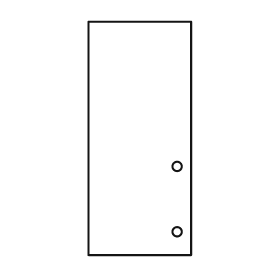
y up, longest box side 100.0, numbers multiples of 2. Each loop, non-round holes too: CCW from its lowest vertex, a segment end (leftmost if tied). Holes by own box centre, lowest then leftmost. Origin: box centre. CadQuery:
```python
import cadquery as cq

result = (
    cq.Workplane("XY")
    .moveTo(-22.0, -50.0)
    .lineTo(22.0, -50.0)
    .lineTo(22.0, 50.0)
    .lineTo(-22.0, 50.0)
    .close()
    .moveTo(16.0, -40.0)
    .circle(2.0)
    .moveTo(16.0, -12.0)
    .circle(2.0)
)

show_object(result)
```